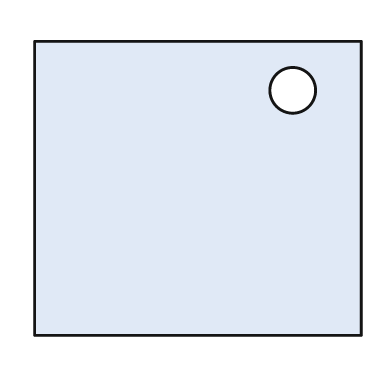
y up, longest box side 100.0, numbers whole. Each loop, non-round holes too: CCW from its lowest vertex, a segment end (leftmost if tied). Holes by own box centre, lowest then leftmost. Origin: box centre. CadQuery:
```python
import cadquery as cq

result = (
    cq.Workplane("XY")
    .moveTo(-50.0, -45.0)
    .lineTo(50.0, -45.0)
    .lineTo(50.0, 45.0)
    .lineTo(-50.0, 45.0)
    .close()
    .moveTo(29.0, 30.0)
    .circle(7.0)
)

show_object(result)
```